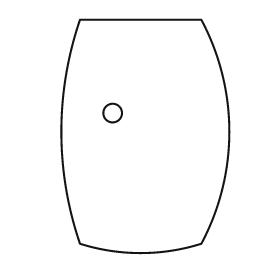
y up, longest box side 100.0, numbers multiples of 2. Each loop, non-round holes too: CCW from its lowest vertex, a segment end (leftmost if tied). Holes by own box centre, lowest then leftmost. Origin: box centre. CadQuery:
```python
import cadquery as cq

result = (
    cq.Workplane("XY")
    .moveTo(-28.0, -46.0)
    .threePointArc((-2.0, -50.0), (24.0, -46.0))
    .threePointArc((36.0, 2.0), (24.0, 50.0))
    .lineTo(-28.0, 50.0)
    .threePointArc((-36.0, 2.0), (-28.0, -46.0))
    .close()
    .moveTo(-14.0, 10.0)
    .circle(4.0)
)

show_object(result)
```